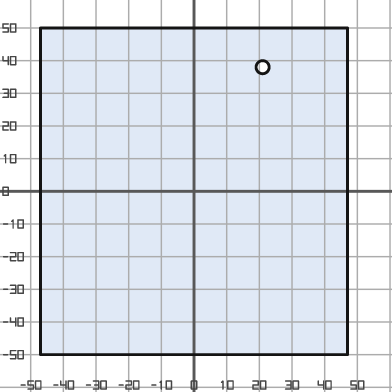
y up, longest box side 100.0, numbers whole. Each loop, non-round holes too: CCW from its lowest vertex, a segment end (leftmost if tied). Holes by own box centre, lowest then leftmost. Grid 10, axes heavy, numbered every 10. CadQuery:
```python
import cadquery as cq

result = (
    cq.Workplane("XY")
    .moveTo(-47.0, -50.0)
    .lineTo(47.0, -50.0)
    .lineTo(47.0, 50.0)
    .lineTo(-47.0, 50.0)
    .close()
    .moveTo(21.0, 38.0)
    .circle(2.0)
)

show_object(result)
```